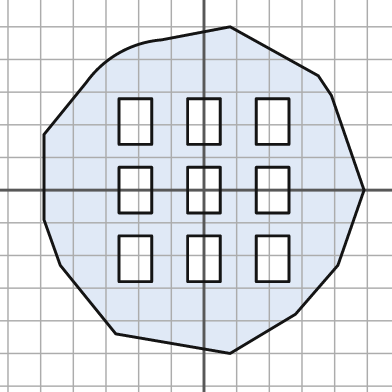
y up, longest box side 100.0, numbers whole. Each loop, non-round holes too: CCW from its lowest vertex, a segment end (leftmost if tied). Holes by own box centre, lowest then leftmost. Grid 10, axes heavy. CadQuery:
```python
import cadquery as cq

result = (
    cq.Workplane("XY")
    .moveTo(8.0, -50.0)
    .lineTo(28.0, -38.0)
    .lineTo(41.0, -23.0)
    .lineTo(49.0, 0.0)
    .lineTo(39.0, 29.0)
    .lineTo(35.0, 35.0)
    .lineTo(8.0, 50.0)
    .lineTo(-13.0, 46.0)
    .threePointArc((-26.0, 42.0), (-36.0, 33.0))
    .lineTo(-49.0, 17.0)
    .lineTo(-49.0, -9.0)
    .lineTo(-44.0, -23.0)
    .lineTo(-27.0, -44.0)
    .close()
    .moveTo(-26.0, -28.0)
    .lineTo(-16.0, -28.0)
    .lineTo(-16.0, -14.0)
    .lineTo(-26.0, -14.0)
    .close()
    .moveTo(-5.0, -28.0)
    .lineTo(5.0, -28.0)
    .lineTo(5.0, -14.0)
    .lineTo(-5.0, -14.0)
    .close()
    .moveTo(16.0, -28.0)
    .lineTo(26.0, -28.0)
    .lineTo(26.0, -14.0)
    .lineTo(16.0, -14.0)
    .close()
    .moveTo(-26.0, -7.0)
    .lineTo(-16.0, -7.0)
    .lineTo(-16.0, 7.0)
    .lineTo(-26.0, 7.0)
    .close()
    .moveTo(-5.0, -7.0)
    .lineTo(5.0, -7.0)
    .lineTo(5.0, 7.0)
    .lineTo(-5.0, 7.0)
    .close()
    .moveTo(16.0, -7.0)
    .lineTo(26.0, -7.0)
    .lineTo(26.0, 7.0)
    .lineTo(16.0, 7.0)
    .close()
    .moveTo(-26.0, 14.0)
    .lineTo(-16.0, 14.0)
    .lineTo(-16.0, 28.0)
    .lineTo(-26.0, 28.0)
    .close()
    .moveTo(-5.0, 14.0)
    .lineTo(5.0, 14.0)
    .lineTo(5.0, 28.0)
    .lineTo(-5.0, 28.0)
    .close()
    .moveTo(16.0, 14.0)
    .lineTo(26.0, 14.0)
    .lineTo(26.0, 28.0)
    .lineTo(16.0, 28.0)
    .close()
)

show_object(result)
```